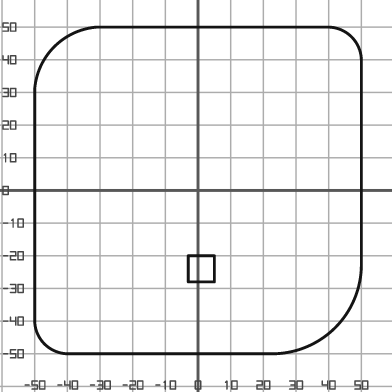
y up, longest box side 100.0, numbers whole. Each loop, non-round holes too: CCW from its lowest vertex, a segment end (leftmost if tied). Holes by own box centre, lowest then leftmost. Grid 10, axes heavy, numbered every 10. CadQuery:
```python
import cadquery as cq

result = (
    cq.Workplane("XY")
    .moveTo(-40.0, -50.0)
    .lineTo(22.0, -50.0)
    .threePointArc((42.0, -42.0), (50.0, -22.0))
    .lineTo(50.0, 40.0)
    .threePointArc((47.0, 47.0), (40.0, 50.0))
    .lineTo(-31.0, 50.0)
    .threePointArc((-44.0, 44.0), (-50.0, 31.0))
    .lineTo(-50.0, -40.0)
    .threePointArc((-47.0, -47.0), (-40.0, -50.0))
    .close()
    .moveTo(-3.0, -28.0)
    .lineTo(5.0, -28.0)
    .lineTo(5.0, -20.0)
    .lineTo(-3.0, -20.0)
    .close()
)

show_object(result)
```